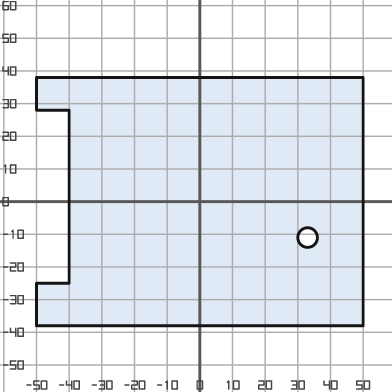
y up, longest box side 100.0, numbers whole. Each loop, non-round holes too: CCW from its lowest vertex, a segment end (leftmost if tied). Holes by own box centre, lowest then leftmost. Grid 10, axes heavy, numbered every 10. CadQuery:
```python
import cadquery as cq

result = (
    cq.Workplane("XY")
    .moveTo(-50.0, -38.0)
    .lineTo(50.0, -38.0)
    .lineTo(50.0, 38.0)
    .lineTo(-50.0, 38.0)
    .lineTo(-50.0, 28.0)
    .lineTo(-40.0, 28.0)
    .lineTo(-40.0, -25.0)
    .lineTo(-50.0, -25.0)
    .close()
    .moveTo(33.0, -11.0)
    .circle(3.0)
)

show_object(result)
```